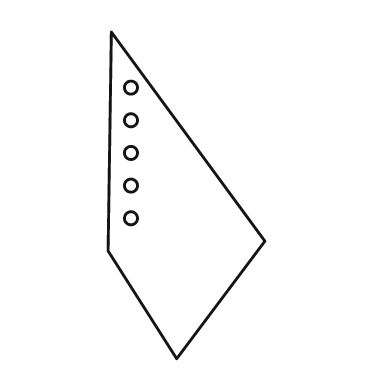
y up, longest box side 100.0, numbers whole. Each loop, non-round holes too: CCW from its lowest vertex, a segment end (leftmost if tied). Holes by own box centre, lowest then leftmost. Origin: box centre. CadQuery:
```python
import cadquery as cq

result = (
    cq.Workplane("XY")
    .moveTo(-3.0, -50.0)
    .lineTo(24.0, -14.0)
    .lineTo(-23.0, 50.0)
    .lineTo(-24.0, -17.0)
    .close()
    .moveTo(-17.0, -7.0)
    .circle(2.0)
    .moveTo(-17.0, 3.0)
    .circle(2.0)
    .moveTo(-17.0, 13.0)
    .circle(2.0)
    .moveTo(-17.0, 23.0)
    .circle(2.0)
    .moveTo(-17.0, 33.0)
    .circle(2.0)
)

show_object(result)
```